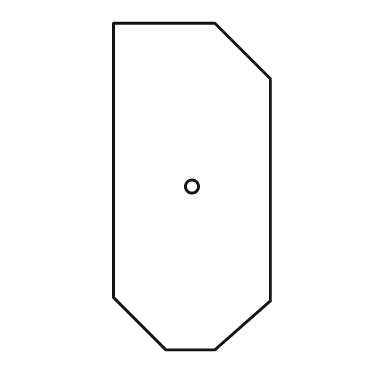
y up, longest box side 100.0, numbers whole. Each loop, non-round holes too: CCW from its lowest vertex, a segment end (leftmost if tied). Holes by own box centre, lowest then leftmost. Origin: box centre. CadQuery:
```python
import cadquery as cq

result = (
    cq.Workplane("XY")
    .moveTo(-8.0, -50.0)
    .lineTo(7.0, -50.0)
    .lineTo(24.0, -35.0)
    .lineTo(24.0, 33.0)
    .lineTo(7.0, 50.0)
    .lineTo(-24.0, 50.0)
    .lineTo(-24.0, -34.0)
    .close()
    .moveTo(0.0, 0.0)
    .circle(2.0)
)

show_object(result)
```